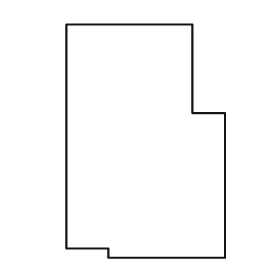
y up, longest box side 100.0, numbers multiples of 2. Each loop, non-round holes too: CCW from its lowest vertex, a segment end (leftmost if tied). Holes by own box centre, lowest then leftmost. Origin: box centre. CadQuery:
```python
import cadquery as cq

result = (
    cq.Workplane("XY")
    .moveTo(-16.0, -50.0)
    .lineTo(34.0, -50.0)
    .lineTo(34.0, 12.0)
    .lineTo(20.0, 12.0)
    .lineTo(20.0, 50.0)
    .lineTo(-34.0, 50.0)
    .lineTo(-34.0, -46.0)
    .lineTo(-16.0, -46.0)
    .close()
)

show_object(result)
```